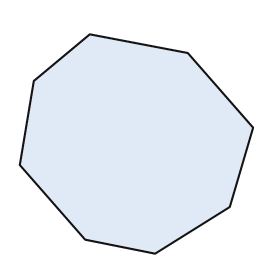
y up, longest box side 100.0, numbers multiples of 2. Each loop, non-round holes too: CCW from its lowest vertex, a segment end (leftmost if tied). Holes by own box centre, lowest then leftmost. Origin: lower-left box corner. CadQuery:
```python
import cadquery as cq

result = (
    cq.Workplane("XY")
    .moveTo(58.0, 0.0)
    .lineTo(90.0, 20.0)
    .lineTo(100.0, 54.0)
    .lineTo(72.0, 86.0)
    .lineTo(30.0, 94.0)
    .lineTo(6.0, 74.0)
    .lineTo(0.0, 38.0)
    .lineTo(28.0, 6.0)
    .close()
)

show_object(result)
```